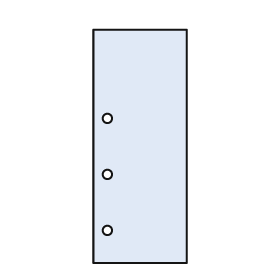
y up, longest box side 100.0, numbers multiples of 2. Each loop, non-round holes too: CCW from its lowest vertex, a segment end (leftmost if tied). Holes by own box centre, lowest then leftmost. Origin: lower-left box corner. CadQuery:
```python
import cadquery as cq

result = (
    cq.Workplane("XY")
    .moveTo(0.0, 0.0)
    .lineTo(40.0, 0.0)
    .lineTo(40.0, 100.0)
    .lineTo(0.0, 100.0)
    .close()
    .moveTo(6.0, 14.0)
    .circle(2.0)
    .moveTo(6.0, 38.0)
    .circle(2.0)
    .moveTo(6.0, 62.0)
    .circle(2.0)
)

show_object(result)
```